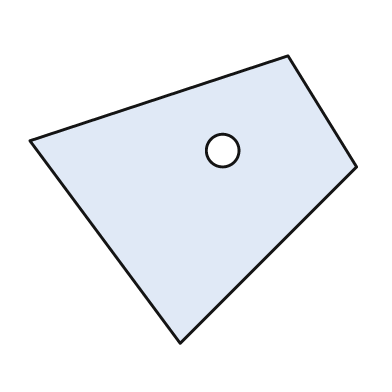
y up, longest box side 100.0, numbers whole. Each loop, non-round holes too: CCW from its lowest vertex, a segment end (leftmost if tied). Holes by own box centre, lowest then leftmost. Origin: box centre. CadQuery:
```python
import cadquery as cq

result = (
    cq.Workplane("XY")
    .moveTo(-4.0, -44.0)
    .lineTo(50.0, 10.0)
    .lineTo(29.0, 44.0)
    .lineTo(-50.0, 18.0)
    .close()
    .moveTo(9.0, 15.0)
    .circle(5.0)
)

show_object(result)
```